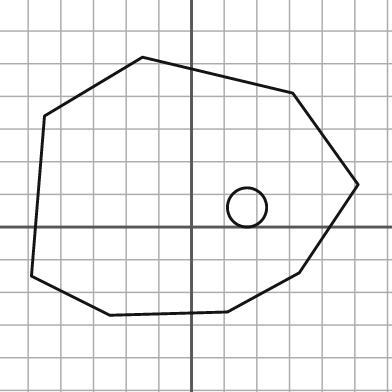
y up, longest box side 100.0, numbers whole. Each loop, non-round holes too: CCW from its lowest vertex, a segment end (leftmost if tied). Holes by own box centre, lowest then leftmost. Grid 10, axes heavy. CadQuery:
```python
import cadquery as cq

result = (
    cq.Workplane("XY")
    .moveTo(-25.0, -27.0)
    .lineTo(11.0, -26.0)
    .lineTo(33.0, -14.0)
    .lineTo(51.0, 13.0)
    .lineTo(31.0, 41.0)
    .lineTo(-15.0, 52.0)
    .lineTo(-45.0, 34.0)
    .lineTo(-49.0, -15.0)
    .close()
    .moveTo(17.0, 6.0)
    .circle(6.0)
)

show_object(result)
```